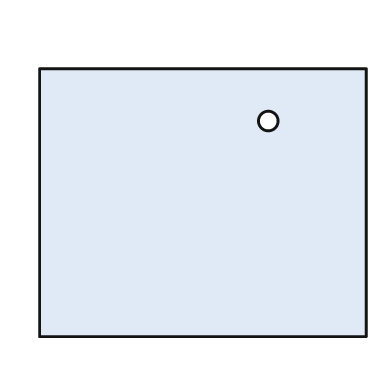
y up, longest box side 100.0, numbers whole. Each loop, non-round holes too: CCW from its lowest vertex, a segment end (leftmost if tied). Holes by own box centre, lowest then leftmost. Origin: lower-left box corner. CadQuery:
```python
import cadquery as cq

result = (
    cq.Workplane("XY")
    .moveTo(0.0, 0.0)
    .lineTo(100.0, 0.0)
    .lineTo(100.0, 82.0)
    .lineTo(0.0, 82.0)
    .close()
    .moveTo(70.0, 66.0)
    .circle(3.0)
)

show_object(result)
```